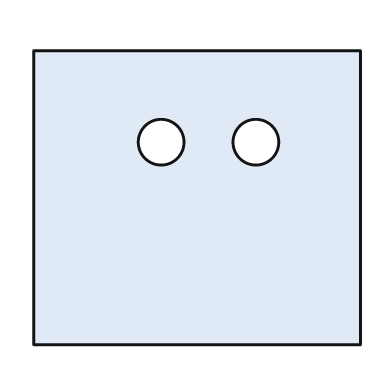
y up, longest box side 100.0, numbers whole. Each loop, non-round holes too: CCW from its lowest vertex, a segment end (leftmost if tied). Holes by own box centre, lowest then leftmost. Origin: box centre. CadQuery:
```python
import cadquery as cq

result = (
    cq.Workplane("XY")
    .moveTo(-50.0, -45.0)
    .lineTo(50.0, -45.0)
    .lineTo(50.0, 45.0)
    .lineTo(-50.0, 45.0)
    .close()
    .moveTo(-11.0, 17.0)
    .circle(7.0)
    .moveTo(18.0, 17.0)
    .circle(7.0)
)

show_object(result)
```